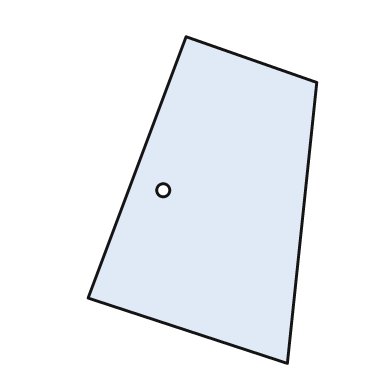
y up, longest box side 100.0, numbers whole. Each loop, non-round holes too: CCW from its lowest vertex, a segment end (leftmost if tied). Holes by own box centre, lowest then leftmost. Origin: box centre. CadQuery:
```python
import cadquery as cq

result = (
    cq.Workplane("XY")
    .moveTo(26.0, -50.0)
    .lineTo(35.0, 36.0)
    .lineTo(-5.0, 50.0)
    .lineTo(-35.0, -30.0)
    .close()
    .moveTo(-12.0, 3.0)
    .circle(2.0)
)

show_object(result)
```